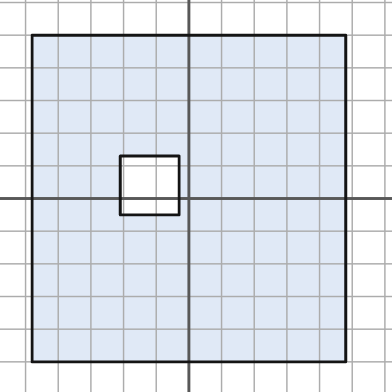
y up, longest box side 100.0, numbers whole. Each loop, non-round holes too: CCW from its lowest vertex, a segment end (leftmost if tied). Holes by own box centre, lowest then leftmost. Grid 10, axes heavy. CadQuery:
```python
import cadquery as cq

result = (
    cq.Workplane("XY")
    .moveTo(-48.0, -50.0)
    .lineTo(48.0, -50.0)
    .lineTo(48.0, 50.0)
    .lineTo(-48.0, 50.0)
    .close()
    .moveTo(-21.0, -5.0)
    .lineTo(-3.0, -5.0)
    .lineTo(-3.0, 13.0)
    .lineTo(-21.0, 13.0)
    .close()
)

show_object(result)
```